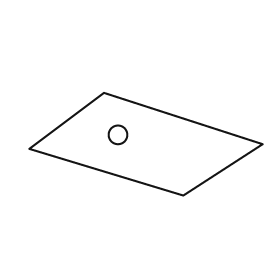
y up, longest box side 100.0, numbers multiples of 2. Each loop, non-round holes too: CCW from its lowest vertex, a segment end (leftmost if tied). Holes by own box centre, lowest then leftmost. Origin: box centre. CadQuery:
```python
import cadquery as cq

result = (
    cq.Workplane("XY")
    .moveTo(16.0, -22.0)
    .lineTo(50.0, 0.0)
    .lineTo(-18.0, 22.0)
    .lineTo(-50.0, -2.0)
    .close()
    .moveTo(-12.0, 4.0)
    .circle(4.0)
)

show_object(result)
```